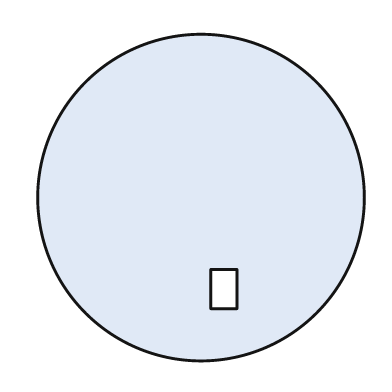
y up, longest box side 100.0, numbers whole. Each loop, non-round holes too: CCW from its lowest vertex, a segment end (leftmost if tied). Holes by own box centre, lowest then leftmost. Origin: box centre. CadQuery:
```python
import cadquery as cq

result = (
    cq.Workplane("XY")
    .moveTo(0.0, 0.0)
    .circle(50.0)
    .moveTo(3.0, -34.0)
    .lineTo(11.0, -34.0)
    .lineTo(11.0, -22.0)
    .lineTo(3.0, -22.0)
    .close()
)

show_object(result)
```